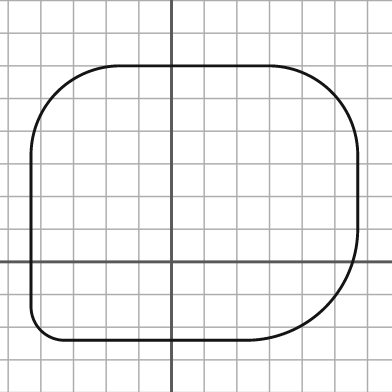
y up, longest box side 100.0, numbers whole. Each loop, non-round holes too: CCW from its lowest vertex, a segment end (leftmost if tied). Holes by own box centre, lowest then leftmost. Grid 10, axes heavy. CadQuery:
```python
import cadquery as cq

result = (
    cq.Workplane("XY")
    .moveTo(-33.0, -24.0)
    .lineTo(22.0, -24.0)
    .threePointArc((47.0, -14.0), (57.0, 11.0))
    .lineTo(57.0, 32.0)
    .threePointArc((49.0, 52.0), (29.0, 60.0))
    .lineTo(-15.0, 60.0)
    .threePointArc((-35.0, 52.0), (-43.0, 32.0))
    .lineTo(-43.0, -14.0)
    .threePointArc((-40.0, -21.0), (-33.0, -24.0))
    .close()
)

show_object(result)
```